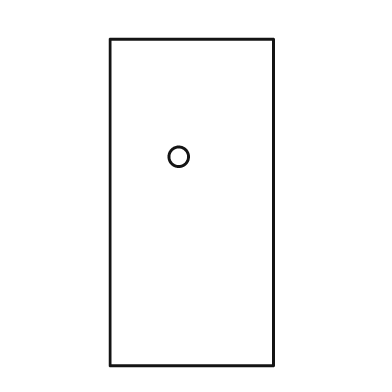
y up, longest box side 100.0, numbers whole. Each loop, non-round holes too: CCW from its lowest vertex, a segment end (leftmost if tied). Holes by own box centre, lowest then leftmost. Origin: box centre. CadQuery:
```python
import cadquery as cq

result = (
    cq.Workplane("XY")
    .moveTo(-25.0, -50.0)
    .lineTo(25.0, -50.0)
    .lineTo(25.0, 50.0)
    .lineTo(-25.0, 50.0)
    .close()
    .moveTo(-4.0, 14.0)
    .circle(3.0)
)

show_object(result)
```